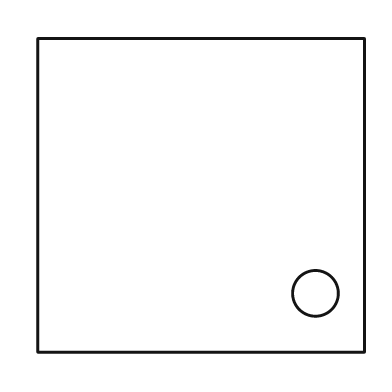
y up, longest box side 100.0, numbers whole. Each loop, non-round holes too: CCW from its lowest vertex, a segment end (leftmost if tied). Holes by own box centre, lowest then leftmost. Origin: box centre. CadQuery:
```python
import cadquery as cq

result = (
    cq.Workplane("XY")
    .moveTo(-50.0, -48.0)
    .lineTo(50.0, -48.0)
    .lineTo(50.0, 48.0)
    .lineTo(-50.0, 48.0)
    .close()
    .moveTo(35.0, -30.0)
    .circle(7.0)
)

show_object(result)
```